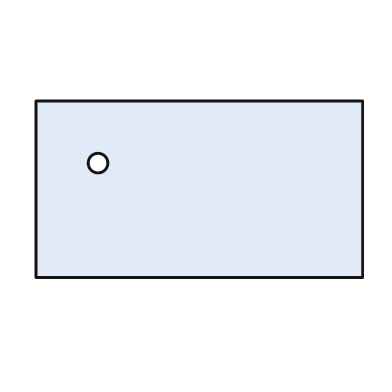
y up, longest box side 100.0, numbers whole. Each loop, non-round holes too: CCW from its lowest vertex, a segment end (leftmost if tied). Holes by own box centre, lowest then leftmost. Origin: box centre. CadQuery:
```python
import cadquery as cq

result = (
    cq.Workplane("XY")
    .moveTo(-50.0, -27.0)
    .lineTo(50.0, -27.0)
    .lineTo(50.0, 27.0)
    .lineTo(-50.0, 27.0)
    .close()
    .moveTo(-31.0, 8.0)
    .circle(3.0)
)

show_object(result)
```